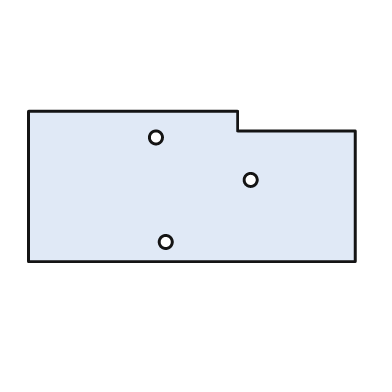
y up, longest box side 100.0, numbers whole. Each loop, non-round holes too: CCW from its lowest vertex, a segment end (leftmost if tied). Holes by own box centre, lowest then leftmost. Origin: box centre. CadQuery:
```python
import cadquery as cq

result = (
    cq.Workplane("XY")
    .moveTo(-50.0, -23.0)
    .lineTo(50.0, -23.0)
    .lineTo(50.0, 17.0)
    .lineTo(14.0, 17.0)
    .lineTo(14.0, 23.0)
    .lineTo(-50.0, 23.0)
    .close()
    .moveTo(-8.0, -17.0)
    .circle(2.0)
    .moveTo(18.0, 2.0)
    .circle(2.0)
    .moveTo(-11.0, 15.0)
    .circle(2.0)
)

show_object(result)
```